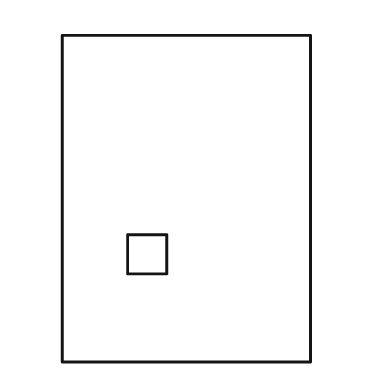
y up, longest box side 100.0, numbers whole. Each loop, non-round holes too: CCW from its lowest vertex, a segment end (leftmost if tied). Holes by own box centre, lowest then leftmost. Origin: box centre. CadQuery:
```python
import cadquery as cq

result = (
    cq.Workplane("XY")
    .moveTo(-38.0, -50.0)
    .lineTo(38.0, -50.0)
    .lineTo(38.0, 50.0)
    .lineTo(-38.0, 50.0)
    .close()
    .moveTo(-18.0, -23.0)
    .lineTo(-6.0, -23.0)
    .lineTo(-6.0, -11.0)
    .lineTo(-18.0, -11.0)
    .close()
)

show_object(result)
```